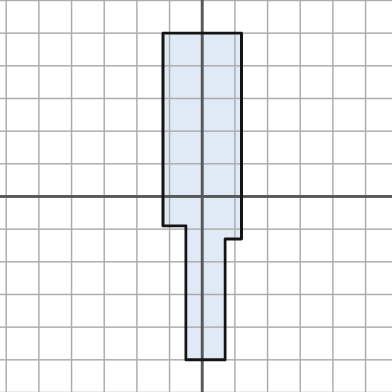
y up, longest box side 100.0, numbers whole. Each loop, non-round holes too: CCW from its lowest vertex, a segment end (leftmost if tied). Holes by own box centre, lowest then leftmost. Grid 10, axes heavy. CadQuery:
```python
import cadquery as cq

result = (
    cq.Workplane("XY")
    .moveTo(-5.0, -50.0)
    .lineTo(7.0, -50.0)
    .lineTo(7.0, -13.0)
    .lineTo(12.0, -13.0)
    .lineTo(12.0, 50.0)
    .lineTo(-12.0, 50.0)
    .lineTo(-12.0, -9.0)
    .lineTo(-5.0, -9.0)
    .close()
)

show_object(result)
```